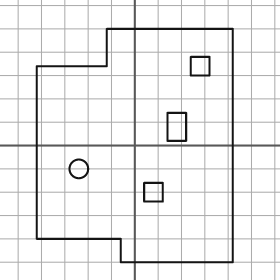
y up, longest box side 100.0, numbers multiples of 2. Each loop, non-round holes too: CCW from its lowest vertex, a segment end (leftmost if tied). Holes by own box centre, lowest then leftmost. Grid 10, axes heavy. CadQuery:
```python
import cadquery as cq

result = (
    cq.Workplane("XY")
    .moveTo(-6.0, -50.0)
    .lineTo(42.0, -50.0)
    .lineTo(42.0, 50.0)
    .lineTo(-12.0, 50.0)
    .lineTo(-12.0, 34.0)
    .lineTo(-42.0, 34.0)
    .lineTo(-42.0, -40.0)
    .lineTo(-6.0, -40.0)
    .close()
    .moveTo(4.0, -24.0)
    .lineTo(12.0, -24.0)
    .lineTo(12.0, -16.0)
    .lineTo(4.0, -16.0)
    .close()
    .moveTo(-24.0, -10.0)
    .circle(4.0)
    .moveTo(14.0, 2.0)
    .lineTo(22.0, 2.0)
    .lineTo(22.0, 14.0)
    .lineTo(14.0, 14.0)
    .close()
    .moveTo(24.0, 30.0)
    .lineTo(32.0, 30.0)
    .lineTo(32.0, 38.0)
    .lineTo(24.0, 38.0)
    .close()
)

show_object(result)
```